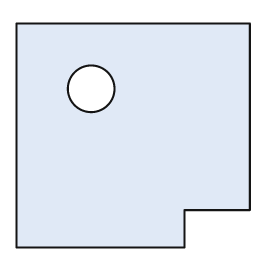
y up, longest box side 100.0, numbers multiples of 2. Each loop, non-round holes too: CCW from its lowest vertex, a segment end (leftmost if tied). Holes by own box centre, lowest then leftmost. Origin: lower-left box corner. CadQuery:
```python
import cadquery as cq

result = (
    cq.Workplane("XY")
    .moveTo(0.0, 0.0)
    .lineTo(72.0, 0.0)
    .lineTo(72.0, 16.0)
    .lineTo(100.0, 16.0)
    .lineTo(100.0, 96.0)
    .lineTo(0.0, 96.0)
    .close()
    .moveTo(32.0, 68.0)
    .circle(10.0)
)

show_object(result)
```